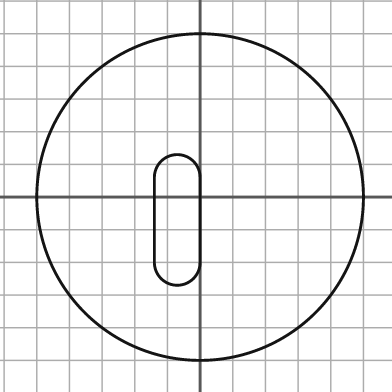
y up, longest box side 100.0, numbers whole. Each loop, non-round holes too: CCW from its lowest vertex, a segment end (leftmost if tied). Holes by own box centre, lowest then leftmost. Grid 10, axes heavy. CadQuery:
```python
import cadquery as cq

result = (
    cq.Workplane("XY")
    .moveTo(0.0, 0.0)
    .circle(50.0)
    .moveTo(-14.0, -20.0)
    .threePointArc((-7.0, -27.0), (0.0, -20.0))
    .lineTo(0.0, 6.0)
    .threePointArc((-7.0, 13.0), (-14.0, 6.0))
    .close()
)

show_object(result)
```